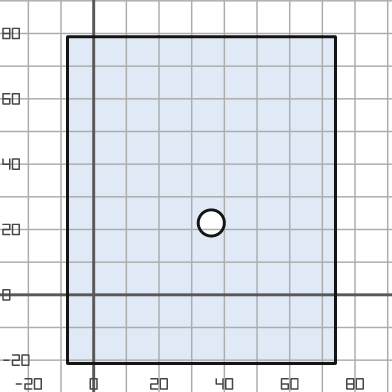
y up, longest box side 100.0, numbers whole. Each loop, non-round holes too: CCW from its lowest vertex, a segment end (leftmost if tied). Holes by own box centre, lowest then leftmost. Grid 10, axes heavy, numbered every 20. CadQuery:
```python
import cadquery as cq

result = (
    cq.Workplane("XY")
    .moveTo(-8.0, -21.0)
    .lineTo(74.0, -21.0)
    .lineTo(74.0, 79.0)
    .lineTo(-8.0, 79.0)
    .close()
    .moveTo(36.0, 22.0)
    .circle(4.0)
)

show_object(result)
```